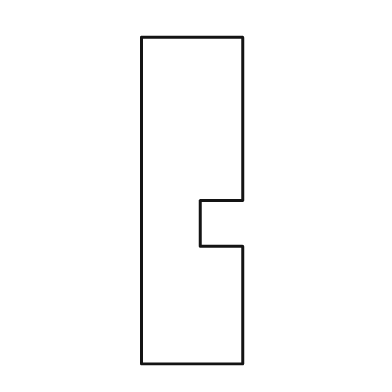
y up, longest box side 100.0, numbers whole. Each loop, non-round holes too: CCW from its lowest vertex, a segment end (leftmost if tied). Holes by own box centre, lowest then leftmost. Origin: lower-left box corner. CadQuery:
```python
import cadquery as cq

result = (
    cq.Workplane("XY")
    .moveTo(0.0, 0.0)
    .lineTo(31.0, 0.0)
    .lineTo(31.0, 36.0)
    .lineTo(18.0, 36.0)
    .lineTo(18.0, 50.0)
    .lineTo(31.0, 50.0)
    .lineTo(31.0, 100.0)
    .lineTo(0.0, 100.0)
    .close()
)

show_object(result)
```